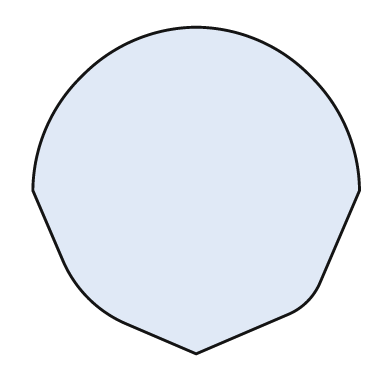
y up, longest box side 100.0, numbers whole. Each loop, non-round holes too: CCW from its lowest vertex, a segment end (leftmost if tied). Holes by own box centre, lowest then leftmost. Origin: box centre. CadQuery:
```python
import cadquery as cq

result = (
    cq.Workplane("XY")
    .moveTo(0.0, -50.0)
    .lineTo(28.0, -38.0)
    .threePointArc((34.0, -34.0), (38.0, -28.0))
    .lineTo(50.0, 0.0)
    .threePointArc((46.0, 19.0), (35.0, 35.0))
    .threePointArc((19.0, 46.0), (0.0, 50.0))
    .threePointArc((-19.0, 46.0), (-35.0, 35.0))
    .threePointArc((-46.0, 19.0), (-50.0, 0.0))
    .lineTo(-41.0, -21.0)
    .threePointArc((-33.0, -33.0), (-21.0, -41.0))
    .close()
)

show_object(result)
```